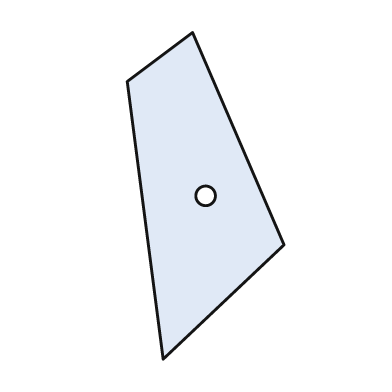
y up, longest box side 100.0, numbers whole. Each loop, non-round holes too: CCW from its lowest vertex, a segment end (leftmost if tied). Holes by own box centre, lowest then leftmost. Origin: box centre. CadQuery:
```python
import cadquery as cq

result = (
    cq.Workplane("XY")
    .moveTo(-13.0, -50.0)
    .lineTo(24.0, -15.0)
    .lineTo(-4.0, 50.0)
    .lineTo(-24.0, 35.0)
    .close()
    .moveTo(0.0, 0.0)
    .circle(3.0)
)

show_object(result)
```